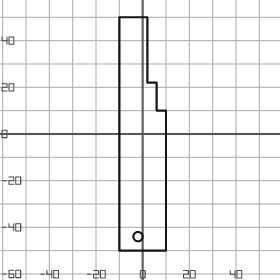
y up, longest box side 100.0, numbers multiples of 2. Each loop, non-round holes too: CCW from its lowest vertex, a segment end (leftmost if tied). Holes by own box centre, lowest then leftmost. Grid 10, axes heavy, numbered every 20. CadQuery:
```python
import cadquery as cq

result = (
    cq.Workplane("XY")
    .moveTo(-10.0, -50.0)
    .lineTo(10.0, -50.0)
    .lineTo(10.0, 10.0)
    .lineTo(6.0, 10.0)
    .lineTo(6.0, 22.0)
    .lineTo(2.0, 22.0)
    .lineTo(2.0, 50.0)
    .lineTo(-10.0, 50.0)
    .close()
    .moveTo(-2.0, -44.0)
    .circle(2.0)
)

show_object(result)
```